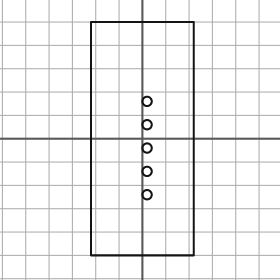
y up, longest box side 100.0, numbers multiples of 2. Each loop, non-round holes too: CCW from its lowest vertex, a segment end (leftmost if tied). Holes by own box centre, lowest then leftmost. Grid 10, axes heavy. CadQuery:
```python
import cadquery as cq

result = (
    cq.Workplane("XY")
    .moveTo(-22.0, -50.0)
    .lineTo(22.0, -50.0)
    .lineTo(22.0, 50.0)
    .lineTo(-22.0, 50.0)
    .close()
    .moveTo(2.0, -24.0)
    .circle(2.0)
    .moveTo(2.0, -14.0)
    .circle(2.0)
    .moveTo(2.0, -4.0)
    .circle(2.0)
    .moveTo(2.0, 6.0)
    .circle(2.0)
    .moveTo(2.0, 16.0)
    .circle(2.0)
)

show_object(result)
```